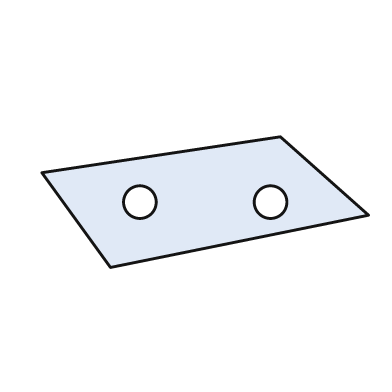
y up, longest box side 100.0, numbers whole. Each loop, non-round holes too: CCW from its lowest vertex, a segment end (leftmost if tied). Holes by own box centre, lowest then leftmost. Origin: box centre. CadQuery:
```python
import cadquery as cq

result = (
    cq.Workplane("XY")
    .moveTo(-29.0, -20.0)
    .lineTo(50.0, -4.0)
    .lineTo(23.0, 20.0)
    .lineTo(-50.0, 9.0)
    .close()
    .moveTo(-20.0, 0.0)
    .circle(5.0)
    .moveTo(20.0, 0.0)
    .circle(5.0)
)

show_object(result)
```